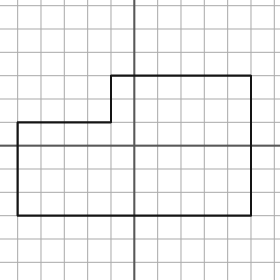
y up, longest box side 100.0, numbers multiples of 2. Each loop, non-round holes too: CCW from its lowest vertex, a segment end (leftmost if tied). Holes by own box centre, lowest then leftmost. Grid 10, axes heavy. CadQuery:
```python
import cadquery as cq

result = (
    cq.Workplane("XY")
    .moveTo(-50.0, -30.0)
    .lineTo(50.0, -30.0)
    .lineTo(50.0, 30.0)
    .lineTo(-10.0, 30.0)
    .lineTo(-10.0, 10.0)
    .lineTo(-50.0, 10.0)
    .close()
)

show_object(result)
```